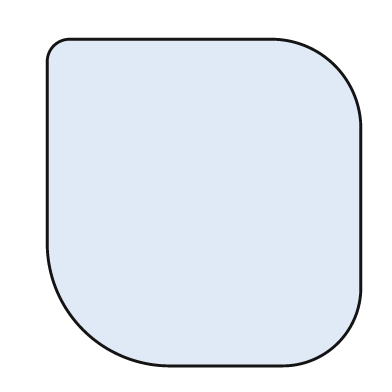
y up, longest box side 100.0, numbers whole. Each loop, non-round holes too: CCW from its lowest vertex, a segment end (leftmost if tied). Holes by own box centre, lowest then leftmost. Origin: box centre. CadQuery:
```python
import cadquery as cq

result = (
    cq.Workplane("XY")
    .moveTo(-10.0, -50.0)
    .lineTo(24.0, -50.0)
    .threePointArc((41.0, -43.0), (48.0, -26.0))
    .lineTo(48.0, 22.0)
    .threePointArc((40.0, 42.0), (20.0, 50.0))
    .lineTo(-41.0, 50.0)
    .threePointArc((-46.0, 48.0), (-48.0, 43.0))
    .lineTo(-48.0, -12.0)
    .threePointArc((-37.0, -39.0), (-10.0, -50.0))
    .close()
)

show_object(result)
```